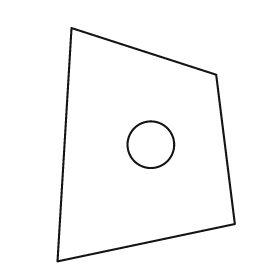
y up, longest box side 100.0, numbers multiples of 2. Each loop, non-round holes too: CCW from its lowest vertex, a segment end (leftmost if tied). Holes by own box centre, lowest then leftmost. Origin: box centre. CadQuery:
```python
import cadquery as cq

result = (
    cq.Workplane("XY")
    .moveTo(-38.0, -50.0)
    .lineTo(38.0, -34.0)
    .lineTo(30.0, 30.0)
    .lineTo(-32.0, 50.0)
    .close()
    .moveTo(2.0, 0.0)
    .circle(10.0)
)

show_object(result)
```